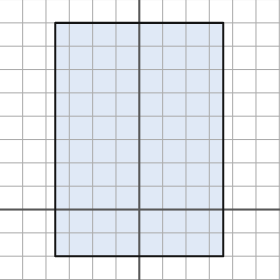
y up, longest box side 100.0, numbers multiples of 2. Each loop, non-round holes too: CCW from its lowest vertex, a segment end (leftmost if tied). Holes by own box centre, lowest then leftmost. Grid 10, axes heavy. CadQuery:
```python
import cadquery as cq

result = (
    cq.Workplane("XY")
    .moveTo(-36.0, -20.0)
    .lineTo(36.0, -20.0)
    .lineTo(36.0, 80.0)
    .lineTo(-36.0, 80.0)
    .close()
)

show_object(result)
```